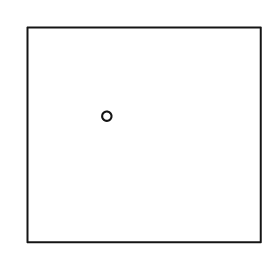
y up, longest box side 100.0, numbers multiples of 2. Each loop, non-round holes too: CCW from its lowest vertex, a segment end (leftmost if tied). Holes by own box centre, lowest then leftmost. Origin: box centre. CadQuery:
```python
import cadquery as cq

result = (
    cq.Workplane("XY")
    .moveTo(-50.0, -46.0)
    .lineTo(50.0, -46.0)
    .lineTo(50.0, 46.0)
    .lineTo(-50.0, 46.0)
    .close()
    .moveTo(-16.0, 8.0)
    .circle(2.0)
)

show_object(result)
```